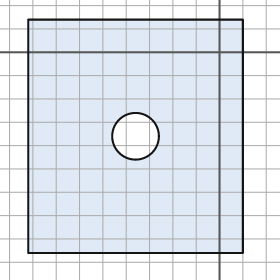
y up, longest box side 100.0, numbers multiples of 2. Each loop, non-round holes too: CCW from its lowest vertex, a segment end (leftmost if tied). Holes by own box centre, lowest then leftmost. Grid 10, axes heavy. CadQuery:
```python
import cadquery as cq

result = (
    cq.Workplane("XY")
    .moveTo(-82.0, -86.0)
    .lineTo(10.0, -86.0)
    .lineTo(10.0, 14.0)
    .lineTo(-82.0, 14.0)
    .close()
    .moveTo(-36.0, -36.0)
    .circle(10.0)
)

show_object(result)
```